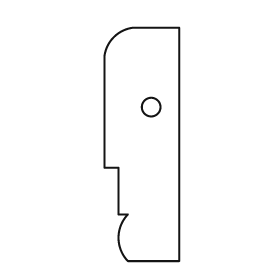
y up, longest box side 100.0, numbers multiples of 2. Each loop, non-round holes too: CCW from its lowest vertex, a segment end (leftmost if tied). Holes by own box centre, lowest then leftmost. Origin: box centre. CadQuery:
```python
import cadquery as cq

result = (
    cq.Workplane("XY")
    .moveTo(-6.0, -50.0)
    .lineTo(16.0, -50.0)
    .lineTo(16.0, 50.0)
    .lineTo(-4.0, 50.0)
    .threePointArc((-12.0, 46.0), (-16.0, 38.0))
    .lineTo(-16.0, -10.0)
    .lineTo(-10.0, -10.0)
    .lineTo(-10.0, -30.0)
    .lineTo(-6.0, -30.0)
    .threePointArc((-10.0, -40.0), (-6.0, -50.0))
    .close()
    .moveTo(4.0, 16.0)
    .circle(4.0)
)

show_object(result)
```